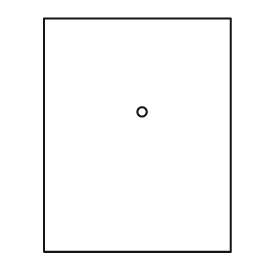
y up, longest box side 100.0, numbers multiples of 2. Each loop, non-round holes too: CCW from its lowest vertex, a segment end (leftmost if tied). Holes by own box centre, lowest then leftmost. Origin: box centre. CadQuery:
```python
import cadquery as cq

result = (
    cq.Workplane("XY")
    .moveTo(-40.0, -50.0)
    .lineTo(40.0, -50.0)
    .lineTo(40.0, 50.0)
    .lineTo(-40.0, 50.0)
    .close()
    .moveTo(2.0, 10.0)
    .circle(2.0)
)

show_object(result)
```